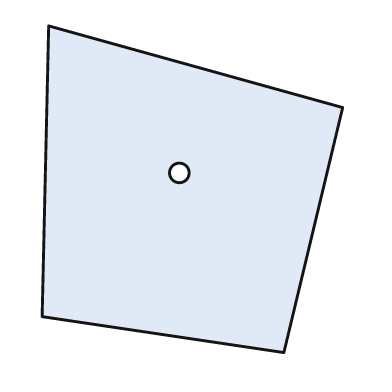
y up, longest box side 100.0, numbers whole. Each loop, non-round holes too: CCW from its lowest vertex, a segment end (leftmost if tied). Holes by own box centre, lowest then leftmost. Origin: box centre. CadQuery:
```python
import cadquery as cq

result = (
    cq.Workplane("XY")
    .moveTo(28.0, -50.0)
    .lineTo(46.0, 25.0)
    .lineTo(-44.0, 50.0)
    .lineTo(-46.0, -39.0)
    .close()
    .moveTo(-4.0, 5.0)
    .circle(3.0)
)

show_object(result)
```